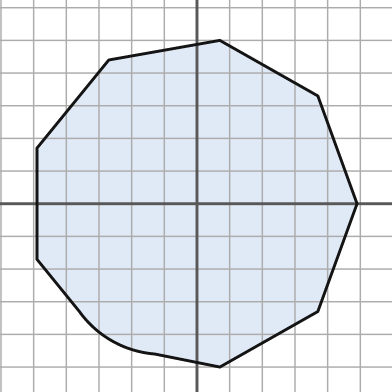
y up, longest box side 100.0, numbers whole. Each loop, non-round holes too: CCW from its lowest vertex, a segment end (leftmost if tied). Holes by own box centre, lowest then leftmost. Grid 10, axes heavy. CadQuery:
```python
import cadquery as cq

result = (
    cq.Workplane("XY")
    .moveTo(7.0, -50.0)
    .lineTo(37.0, -33.0)
    .lineTo(49.0, 0.0)
    .lineTo(37.0, 33.0)
    .lineTo(7.0, 50.0)
    .lineTo(-27.0, 44.0)
    .lineTo(-49.0, 17.0)
    .lineTo(-49.0, -17.0)
    .lineTo(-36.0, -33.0)
    .threePointArc((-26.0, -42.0), (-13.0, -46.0))
    .close()
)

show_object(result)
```